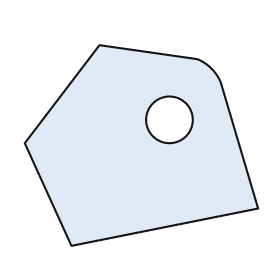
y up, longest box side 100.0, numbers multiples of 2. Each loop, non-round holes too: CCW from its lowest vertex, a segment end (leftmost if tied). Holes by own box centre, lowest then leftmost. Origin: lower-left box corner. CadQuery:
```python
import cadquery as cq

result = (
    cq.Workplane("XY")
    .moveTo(20.0, 0.0)
    .lineTo(100.0, 16.0)
    .lineTo(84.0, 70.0)
    .threePointArc((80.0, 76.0), (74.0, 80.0))
    .lineTo(32.0, 86.0)
    .lineTo(0.0, 44.0)
    .close()
    .moveTo(62.0, 54.0)
    .circle(10.0)
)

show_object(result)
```